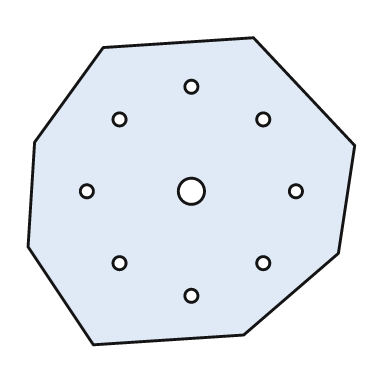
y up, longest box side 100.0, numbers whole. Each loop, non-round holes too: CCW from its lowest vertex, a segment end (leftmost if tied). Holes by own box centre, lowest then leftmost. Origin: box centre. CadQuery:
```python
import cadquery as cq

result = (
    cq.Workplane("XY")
    .moveTo(-30.0, -47.0)
    .lineTo(16.0, -44.0)
    .lineTo(45.0, -19.0)
    .lineTo(50.0, 14.0)
    .lineTo(19.0, 47.0)
    .lineTo(-27.0, 44.0)
    .lineTo(-48.0, 15.0)
    .lineTo(-50.0, -17.0)
    .close()
    .moveTo(0.0, -32.0)
    .circle(2.0)
    .moveTo(-22.0, -22.0)
    .circle(2.0)
    .moveTo(22.0, -22.0)
    .circle(2.0)
    .moveTo(-32.0, 0.0)
    .circle(2.0)
    .moveTo(0.0, 0.0)
    .circle(4.0)
    .moveTo(32.0, 0.0)
    .circle(2.0)
    .moveTo(-22.0, 22.0)
    .circle(2.0)
    .moveTo(22.0, 22.0)
    .circle(2.0)
    .moveTo(0.0, 32.0)
    .circle(2.0)
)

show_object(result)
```